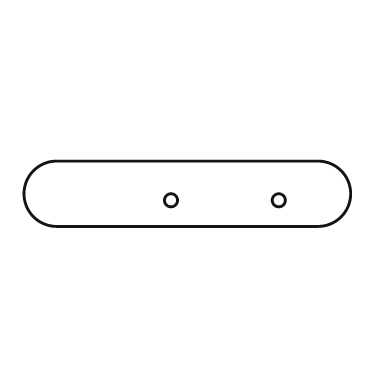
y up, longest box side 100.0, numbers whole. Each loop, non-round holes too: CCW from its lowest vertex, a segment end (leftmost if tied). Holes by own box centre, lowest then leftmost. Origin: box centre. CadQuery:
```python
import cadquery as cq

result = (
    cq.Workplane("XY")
    .moveTo(-40.0, -10.0)
    .lineTo(40.0, -10.0)
    .threePointArc((50.0, 0.0), (40.0, 10.0))
    .lineTo(-40.0, 10.0)
    .threePointArc((-50.0, 0.0), (-40.0, -10.0))
    .close()
    .moveTo(-5.0, -2.0)
    .circle(2.0)
    .moveTo(28.0, -2.0)
    .circle(2.0)
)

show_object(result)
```